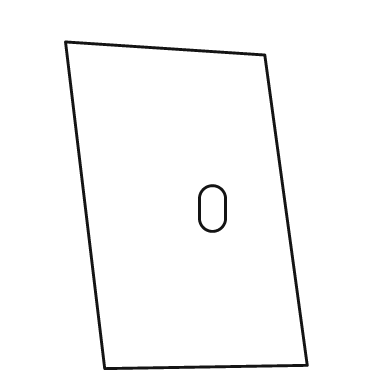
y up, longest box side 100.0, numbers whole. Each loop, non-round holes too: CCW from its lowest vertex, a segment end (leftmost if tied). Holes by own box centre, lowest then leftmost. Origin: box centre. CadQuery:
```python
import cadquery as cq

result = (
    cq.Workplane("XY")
    .moveTo(-25.0, -50.0)
    .lineTo(37.0, -49.0)
    .lineTo(24.0, 46.0)
    .lineTo(-37.0, 50.0)
    .close()
    .moveTo(4.0, -4.0)
    .threePointArc((8.0, -8.0), (12.0, -4.0))
    .lineTo(12.0, 2.0)
    .threePointArc((8.0, 6.0), (4.0, 2.0))
    .close()
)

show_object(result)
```